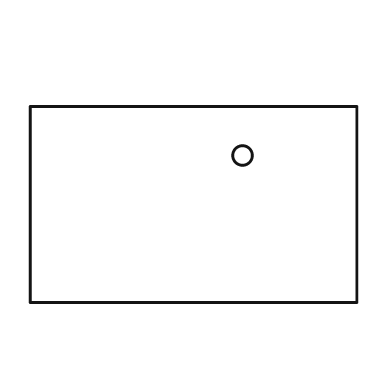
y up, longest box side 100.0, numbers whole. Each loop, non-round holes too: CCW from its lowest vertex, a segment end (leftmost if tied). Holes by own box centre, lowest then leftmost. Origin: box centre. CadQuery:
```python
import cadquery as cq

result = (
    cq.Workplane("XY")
    .moveTo(-50.0, -30.0)
    .lineTo(50.0, -30.0)
    .lineTo(50.0, 30.0)
    .lineTo(-50.0, 30.0)
    .close()
    .moveTo(15.0, 15.0)
    .circle(3.0)
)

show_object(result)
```